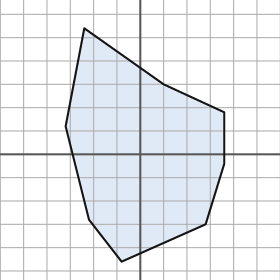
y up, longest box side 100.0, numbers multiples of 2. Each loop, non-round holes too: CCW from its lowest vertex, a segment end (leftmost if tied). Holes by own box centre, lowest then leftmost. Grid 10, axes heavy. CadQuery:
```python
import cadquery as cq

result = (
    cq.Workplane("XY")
    .moveTo(-8.0, -46.0)
    .lineTo(28.0, -30.0)
    .lineTo(36.0, -4.0)
    .lineTo(36.0, 18.0)
    .lineTo(10.0, 30.0)
    .lineTo(-24.0, 54.0)
    .lineTo(-32.0, 12.0)
    .lineTo(-22.0, -28.0)
    .close()
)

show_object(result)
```